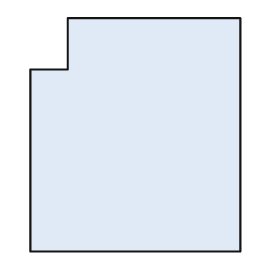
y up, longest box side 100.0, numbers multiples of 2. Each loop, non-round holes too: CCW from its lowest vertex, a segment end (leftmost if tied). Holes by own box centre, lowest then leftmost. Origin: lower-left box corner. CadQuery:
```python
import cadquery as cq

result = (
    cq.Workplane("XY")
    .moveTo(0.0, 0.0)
    .lineTo(90.0, 0.0)
    .lineTo(90.0, 100.0)
    .lineTo(16.0, 100.0)
    .lineTo(16.0, 78.0)
    .lineTo(0.0, 78.0)
    .close()
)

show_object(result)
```